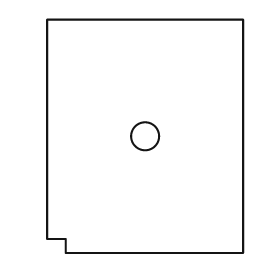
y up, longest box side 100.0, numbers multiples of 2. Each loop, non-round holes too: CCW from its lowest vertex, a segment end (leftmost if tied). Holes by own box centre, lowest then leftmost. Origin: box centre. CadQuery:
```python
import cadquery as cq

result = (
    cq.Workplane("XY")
    .moveTo(-34.0, -50.0)
    .lineTo(42.0, -50.0)
    .lineTo(42.0, 50.0)
    .lineTo(-42.0, 50.0)
    .lineTo(-42.0, -44.0)
    .lineTo(-34.0, -44.0)
    .close()
    .moveTo(0.0, 0.0)
    .circle(6.0)
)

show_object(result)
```